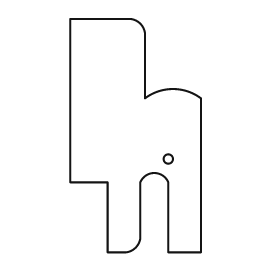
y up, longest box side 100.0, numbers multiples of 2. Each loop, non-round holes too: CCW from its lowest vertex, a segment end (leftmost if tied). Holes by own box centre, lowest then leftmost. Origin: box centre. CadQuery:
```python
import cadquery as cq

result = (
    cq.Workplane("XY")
    .moveTo(-12.0, -50.0)
    .lineTo(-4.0, -50.0)
    .threePointArc((0.0, -48.0), (2.0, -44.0))
    .lineTo(2.0, -20.0)
    .threePointArc((8.0, -16.0), (14.0, -20.0))
    .lineTo(14.0, -50.0)
    .lineTo(28.0, -50.0)
    .lineTo(28.0, 16.0)
    .threePointArc((16.0, 20.0), (4.0, 16.0))
    .lineTo(4.0, 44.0)
    .threePointArc((2.0, 48.0), (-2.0, 50.0))
    .lineTo(-28.0, 50.0)
    .lineTo(-28.0, -20.0)
    .lineTo(-12.0, -20.0)
    .close()
    .moveTo(14.0, -10.0)
    .circle(2.0)
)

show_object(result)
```